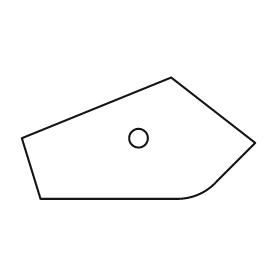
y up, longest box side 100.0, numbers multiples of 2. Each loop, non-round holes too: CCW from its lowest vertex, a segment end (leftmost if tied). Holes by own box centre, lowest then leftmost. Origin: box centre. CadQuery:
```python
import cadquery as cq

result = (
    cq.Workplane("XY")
    .moveTo(-42.0, -26.0)
    .lineTo(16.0, -26.0)
    .threePointArc((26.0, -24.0), (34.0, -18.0))
    .lineTo(50.0, -2.0)
    .lineTo(14.0, 26.0)
    .lineTo(-50.0, 0.0)
    .close()
    .moveTo(0.0, 0.0)
    .circle(4.0)
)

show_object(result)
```